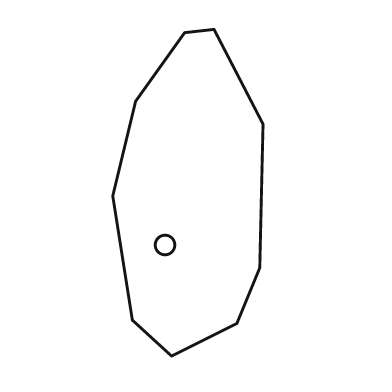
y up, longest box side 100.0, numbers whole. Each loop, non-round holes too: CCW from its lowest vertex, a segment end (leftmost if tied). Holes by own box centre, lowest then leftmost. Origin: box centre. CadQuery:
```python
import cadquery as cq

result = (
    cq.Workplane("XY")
    .moveTo(-5.0, -50.0)
    .lineTo(15.0, -40.0)
    .lineTo(22.0, -23.0)
    .lineTo(23.0, 21.0)
    .lineTo(8.0, 50.0)
    .lineTo(-1.0, 49.0)
    .lineTo(-16.0, 28.0)
    .lineTo(-23.0, -1.0)
    .lineTo(-17.0, -39.0)
    .close()
    .moveTo(-7.0, -16.0)
    .circle(3.0)
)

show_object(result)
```